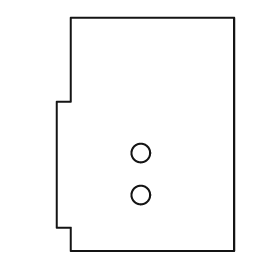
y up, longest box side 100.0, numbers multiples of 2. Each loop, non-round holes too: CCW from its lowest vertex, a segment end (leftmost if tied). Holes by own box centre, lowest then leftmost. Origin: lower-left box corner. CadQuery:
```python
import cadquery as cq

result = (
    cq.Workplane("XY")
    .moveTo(6.0, 0.0)
    .lineTo(76.0, 0.0)
    .lineTo(76.0, 100.0)
    .lineTo(6.0, 100.0)
    .lineTo(6.0, 64.0)
    .lineTo(0.0, 64.0)
    .lineTo(0.0, 10.0)
    .lineTo(6.0, 10.0)
    .close()
    .moveTo(36.0, 24.0)
    .circle(4.0)
    .moveTo(36.0, 42.0)
    .circle(4.0)
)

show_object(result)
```